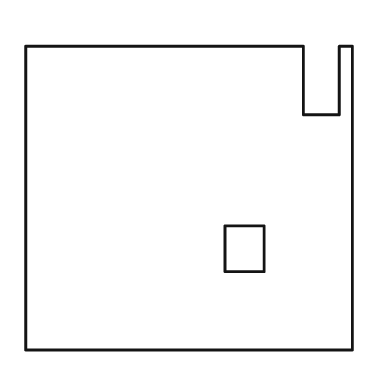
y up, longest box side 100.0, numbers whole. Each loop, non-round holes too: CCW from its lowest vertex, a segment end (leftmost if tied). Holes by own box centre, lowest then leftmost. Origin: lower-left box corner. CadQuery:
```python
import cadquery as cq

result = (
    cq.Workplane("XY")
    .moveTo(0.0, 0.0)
    .lineTo(100.0, 0.0)
    .lineTo(100.0, 93.0)
    .lineTo(96.0, 93.0)
    .lineTo(96.0, 72.0)
    .lineTo(85.0, 72.0)
    .lineTo(85.0, 93.0)
    .lineTo(0.0, 93.0)
    .close()
    .moveTo(61.0, 24.0)
    .lineTo(73.0, 24.0)
    .lineTo(73.0, 38.0)
    .lineTo(61.0, 38.0)
    .close()
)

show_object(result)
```